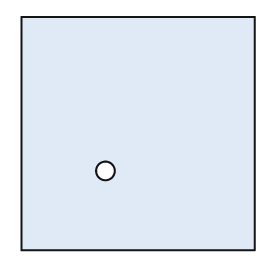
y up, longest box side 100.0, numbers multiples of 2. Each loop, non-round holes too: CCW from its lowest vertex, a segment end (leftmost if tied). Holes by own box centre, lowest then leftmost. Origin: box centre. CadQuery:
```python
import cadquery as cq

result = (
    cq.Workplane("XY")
    .moveTo(-50.0, -50.0)
    .lineTo(50.0, -50.0)
    .lineTo(50.0, 50.0)
    .lineTo(-50.0, 50.0)
    .close()
    .moveTo(-14.0, -16.0)
    .circle(4.0)
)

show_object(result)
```